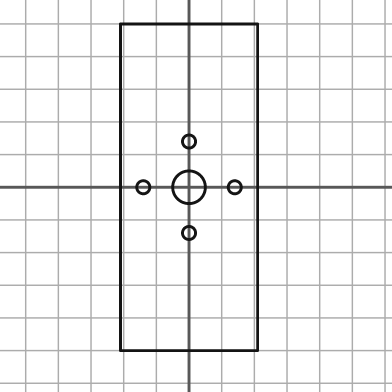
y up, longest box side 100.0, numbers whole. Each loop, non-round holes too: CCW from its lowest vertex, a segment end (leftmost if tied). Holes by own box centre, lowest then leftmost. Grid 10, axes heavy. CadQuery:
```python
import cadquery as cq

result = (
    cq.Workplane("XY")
    .moveTo(-21.0, -50.0)
    .lineTo(21.0, -50.0)
    .lineTo(21.0, 50.0)
    .lineTo(-21.0, 50.0)
    .close()
    .moveTo(0.0, -14.0)
    .circle(2.0)
    .moveTo(-14.0, 0.0)
    .circle(2.0)
    .moveTo(0.0, 0.0)
    .circle(5.0)
    .moveTo(14.0, 0.0)
    .circle(2.0)
    .moveTo(0.0, 14.0)
    .circle(2.0)
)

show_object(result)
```